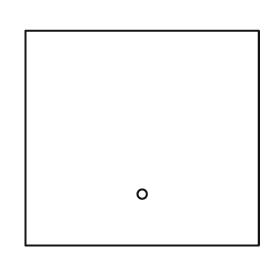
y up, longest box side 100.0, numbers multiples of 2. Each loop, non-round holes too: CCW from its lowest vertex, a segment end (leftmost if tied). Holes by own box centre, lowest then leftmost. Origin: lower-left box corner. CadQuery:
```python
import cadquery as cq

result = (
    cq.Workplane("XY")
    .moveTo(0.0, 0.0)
    .lineTo(100.0, 0.0)
    .lineTo(100.0, 92.0)
    .lineTo(0.0, 92.0)
    .close()
    .moveTo(50.0, 22.0)
    .circle(2.0)
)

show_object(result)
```